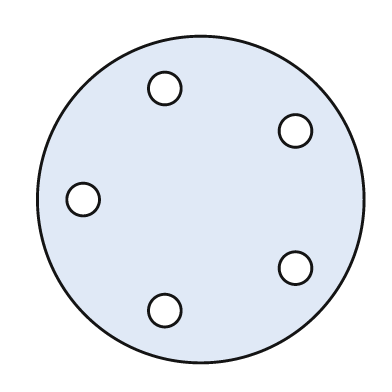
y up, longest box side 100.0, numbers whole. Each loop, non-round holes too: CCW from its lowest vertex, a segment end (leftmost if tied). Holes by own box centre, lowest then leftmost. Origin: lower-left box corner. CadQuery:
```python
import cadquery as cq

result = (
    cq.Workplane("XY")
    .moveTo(50.0, 50.0)
    .circle(50.0)
    .moveTo(39.0, 16.0)
    .circle(5.0)
    .moveTo(79.0, 29.0)
    .circle(5.0)
    .moveTo(14.0, 50.0)
    .circle(5.0)
    .moveTo(79.0, 71.0)
    .circle(5.0)
    .moveTo(39.0, 84.0)
    .circle(5.0)
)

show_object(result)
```